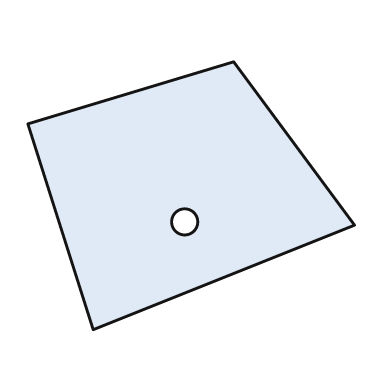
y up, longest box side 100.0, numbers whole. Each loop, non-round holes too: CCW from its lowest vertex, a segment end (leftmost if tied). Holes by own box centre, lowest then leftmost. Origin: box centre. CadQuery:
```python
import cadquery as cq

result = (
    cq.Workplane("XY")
    .moveTo(-30.0, -41.0)
    .lineTo(50.0, -9.0)
    .lineTo(13.0, 41.0)
    .lineTo(-50.0, 22.0)
    .close()
    .moveTo(-2.0, -8.0)
    .circle(4.0)
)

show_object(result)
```